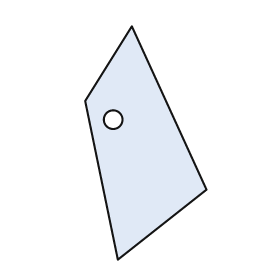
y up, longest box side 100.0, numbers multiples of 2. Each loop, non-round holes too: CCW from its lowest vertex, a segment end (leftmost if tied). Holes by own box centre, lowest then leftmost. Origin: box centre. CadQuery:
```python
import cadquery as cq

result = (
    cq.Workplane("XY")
    .moveTo(-12.0, -50.0)
    .lineTo(26.0, -20.0)
    .lineTo(-6.0, 50.0)
    .lineTo(-26.0, 18.0)
    .close()
    .moveTo(-14.0, 10.0)
    .circle(4.0)
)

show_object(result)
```